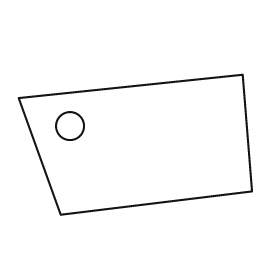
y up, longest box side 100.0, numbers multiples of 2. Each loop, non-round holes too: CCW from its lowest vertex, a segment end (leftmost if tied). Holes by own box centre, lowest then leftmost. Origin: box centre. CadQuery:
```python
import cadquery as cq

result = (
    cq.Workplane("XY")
    .moveTo(-32.0, -30.0)
    .lineTo(50.0, -20.0)
    .lineTo(46.0, 30.0)
    .lineTo(-50.0, 20.0)
    .close()
    .moveTo(-28.0, 8.0)
    .circle(6.0)
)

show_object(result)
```